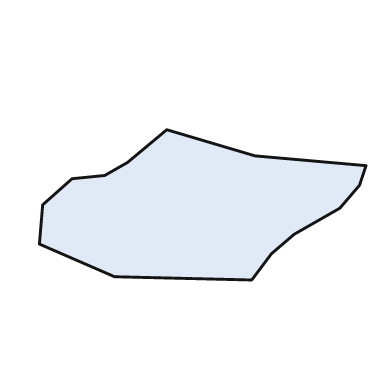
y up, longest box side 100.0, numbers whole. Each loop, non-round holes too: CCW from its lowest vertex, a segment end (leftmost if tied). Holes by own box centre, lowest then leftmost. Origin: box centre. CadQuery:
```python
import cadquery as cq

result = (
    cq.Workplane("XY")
    .moveTo(15.0, -23.0)
    .lineTo(21.0, -15.0)
    .lineTo(28.0, -9.0)
    .lineTo(42.0, -1.0)
    .lineTo(48.0, 6.0)
    .lineTo(50.0, 12.0)
    .lineTo(16.0, 15.0)
    .lineTo(-11.0, 23.0)
    .lineTo(-23.0, 13.0)
    .lineTo(-30.0, 9.0)
    .lineTo(-40.0, 8.0)
    .lineTo(-49.0, 0.0)
    .lineTo(-50.0, -12.0)
    .lineTo(-27.0, -22.0)
    .close()
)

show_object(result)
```